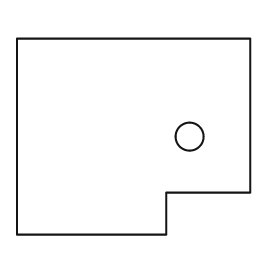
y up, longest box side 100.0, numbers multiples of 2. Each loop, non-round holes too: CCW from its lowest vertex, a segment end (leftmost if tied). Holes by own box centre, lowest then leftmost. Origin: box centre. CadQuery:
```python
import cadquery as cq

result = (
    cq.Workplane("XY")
    .moveTo(-50.0, -42.0)
    .lineTo(14.0, -42.0)
    .lineTo(14.0, -24.0)
    .lineTo(50.0, -24.0)
    .lineTo(50.0, 42.0)
    .lineTo(-50.0, 42.0)
    .close()
    .moveTo(24.0, 0.0)
    .circle(6.0)
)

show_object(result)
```